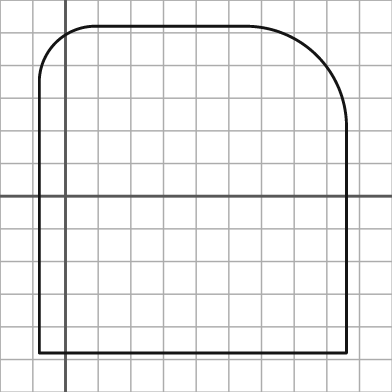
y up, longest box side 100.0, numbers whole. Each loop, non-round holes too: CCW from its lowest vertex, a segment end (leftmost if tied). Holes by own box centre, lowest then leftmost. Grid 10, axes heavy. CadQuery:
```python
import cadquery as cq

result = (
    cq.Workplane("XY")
    .moveTo(-8.0, -48.0)
    .lineTo(86.0, -48.0)
    .lineTo(86.0, 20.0)
    .threePointArc((77.0, 43.0), (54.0, 52.0))
    .lineTo(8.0, 52.0)
    .threePointArc((-3.0, 47.0), (-8.0, 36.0))
    .close()
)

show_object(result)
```